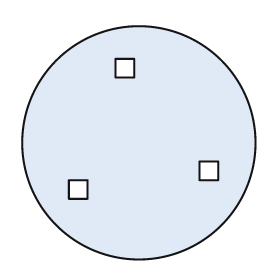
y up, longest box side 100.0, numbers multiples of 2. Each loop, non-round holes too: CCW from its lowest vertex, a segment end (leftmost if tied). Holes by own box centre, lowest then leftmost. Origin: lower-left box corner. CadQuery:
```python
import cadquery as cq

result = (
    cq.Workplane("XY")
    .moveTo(50.0, 50.0)
    .circle(50.0)
    .moveTo(20.0, 26.0)
    .lineTo(28.0, 26.0)
    .lineTo(28.0, 34.0)
    .lineTo(20.0, 34.0)
    .close()
    .moveTo(76.0, 34.0)
    .lineTo(84.0, 34.0)
    .lineTo(84.0, 42.0)
    .lineTo(76.0, 42.0)
    .close()
    .moveTo(40.0, 78.0)
    .lineTo(48.0, 78.0)
    .lineTo(48.0, 86.0)
    .lineTo(40.0, 86.0)
    .close()
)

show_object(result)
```